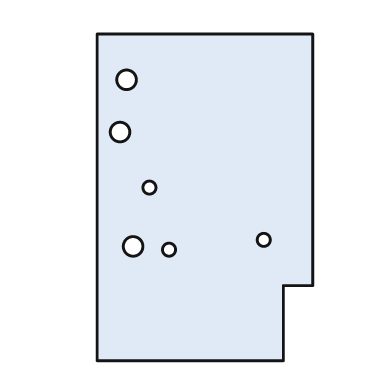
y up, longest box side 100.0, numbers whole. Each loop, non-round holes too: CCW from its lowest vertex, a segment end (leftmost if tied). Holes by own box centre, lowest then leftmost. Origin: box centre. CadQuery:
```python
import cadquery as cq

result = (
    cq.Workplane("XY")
    .moveTo(-33.0, -50.0)
    .lineTo(24.0, -50.0)
    .lineTo(24.0, -27.0)
    .lineTo(33.0, -27.0)
    .lineTo(33.0, 50.0)
    .lineTo(-33.0, 50.0)
    .close()
    .moveTo(-11.0, -16.0)
    .circle(2.0)
    .moveTo(-22.0, -15.0)
    .circle(3.0)
    .moveTo(18.0, -13.0)
    .circle(2.0)
    .moveTo(-17.0, 3.0)
    .circle(2.0)
    .moveTo(-26.0, 20.0)
    .circle(3.0)
    .moveTo(-24.0, 36.0)
    .circle(3.0)
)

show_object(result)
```